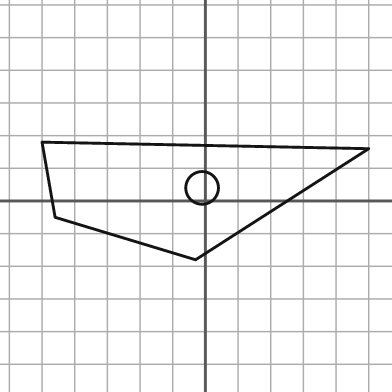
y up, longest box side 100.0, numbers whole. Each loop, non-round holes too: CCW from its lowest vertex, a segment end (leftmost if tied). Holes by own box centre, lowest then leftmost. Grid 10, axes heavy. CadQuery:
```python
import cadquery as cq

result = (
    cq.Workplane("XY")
    .moveTo(-3.0, -18.0)
    .lineTo(50.0, 16.0)
    .lineTo(-50.0, 18.0)
    .lineTo(-46.0, -5.0)
    .close()
    .moveTo(-1.0, 4.0)
    .circle(5.0)
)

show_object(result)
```